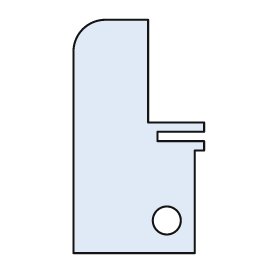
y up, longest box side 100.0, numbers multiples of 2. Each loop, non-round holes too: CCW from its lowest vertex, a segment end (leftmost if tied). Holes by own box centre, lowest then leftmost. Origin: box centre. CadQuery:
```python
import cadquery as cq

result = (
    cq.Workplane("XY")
    .moveTo(-28.0, -50.0)
    .lineTo(24.0, -50.0)
    .lineTo(24.0, -6.0)
    .lineTo(28.0, -6.0)
    .lineTo(28.0, -2.0)
    .lineTo(8.0, -2.0)
    .lineTo(8.0, 2.0)
    .lineTo(28.0, 2.0)
    .lineTo(28.0, 6.0)
    .lineTo(4.0, 6.0)
    .lineTo(4.0, 50.0)
    .lineTo(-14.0, 50.0)
    .threePointArc((-24.0, 46.0), (-28.0, 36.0))
    .close()
    .moveTo(12.0, -36.0)
    .circle(6.0)
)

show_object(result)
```